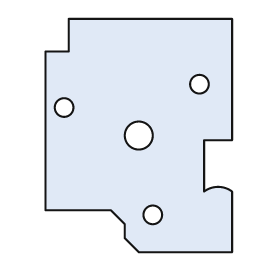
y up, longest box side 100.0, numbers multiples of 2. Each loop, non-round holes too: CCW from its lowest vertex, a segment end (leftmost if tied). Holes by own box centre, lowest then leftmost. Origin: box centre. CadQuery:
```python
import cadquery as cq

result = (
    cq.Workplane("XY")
    .moveTo(0.0, -50.0)
    .lineTo(40.0, -50.0)
    .lineTo(40.0, -24.0)
    .threePointArc((34.0, -22.0), (28.0, -24.0))
    .lineTo(28.0, -2.0)
    .lineTo(40.0, -2.0)
    .lineTo(40.0, 50.0)
    .lineTo(-30.0, 50.0)
    .lineTo(-30.0, 36.0)
    .lineTo(-40.0, 36.0)
    .lineTo(-40.0, -32.0)
    .lineTo(-12.0, -32.0)
    .lineTo(-6.0, -38.0)
    .lineTo(-6.0, -44.0)
    .close()
    .moveTo(6.0, -34.0)
    .circle(4.0)
    .moveTo(0.0, 0.0)
    .circle(6.0)
    .moveTo(-32.0, 12.0)
    .circle(4.0)
    .moveTo(26.0, 22.0)
    .circle(4.0)
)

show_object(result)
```